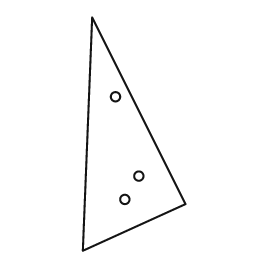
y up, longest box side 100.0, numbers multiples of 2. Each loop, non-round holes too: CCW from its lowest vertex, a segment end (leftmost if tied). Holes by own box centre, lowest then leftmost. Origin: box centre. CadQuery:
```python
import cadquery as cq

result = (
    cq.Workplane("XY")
    .moveTo(-22.0, -50.0)
    .lineTo(22.0, -30.0)
    .lineTo(-18.0, 50.0)
    .close()
    .moveTo(-4.0, -28.0)
    .circle(2.0)
    .moveTo(2.0, -18.0)
    .circle(2.0)
    .moveTo(-8.0, 16.0)
    .circle(2.0)
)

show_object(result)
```